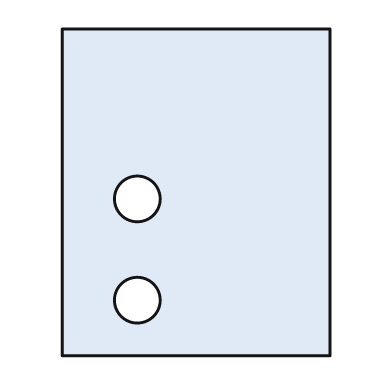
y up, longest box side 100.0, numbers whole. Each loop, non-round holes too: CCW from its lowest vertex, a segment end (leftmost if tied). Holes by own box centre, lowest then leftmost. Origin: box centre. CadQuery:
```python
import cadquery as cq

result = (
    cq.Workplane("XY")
    .moveTo(-41.0, -50.0)
    .lineTo(41.0, -50.0)
    .lineTo(41.0, 50.0)
    .lineTo(-41.0, 50.0)
    .close()
    .moveTo(-18.0, -33.0)
    .circle(7.0)
    .moveTo(-18.0, -2.0)
    .circle(7.0)
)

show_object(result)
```